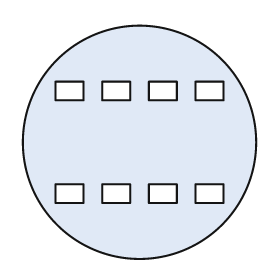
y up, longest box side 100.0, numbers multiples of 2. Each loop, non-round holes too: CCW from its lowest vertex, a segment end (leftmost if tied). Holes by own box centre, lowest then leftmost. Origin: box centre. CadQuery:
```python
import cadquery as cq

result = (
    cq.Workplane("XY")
    .moveTo(0.0, 0.0)
    .circle(50.0)
    .moveTo(-36.0, -26.0)
    .lineTo(-24.0, -26.0)
    .lineTo(-24.0, -18.0)
    .lineTo(-36.0, -18.0)
    .close()
    .moveTo(-16.0, -26.0)
    .lineTo(-4.0, -26.0)
    .lineTo(-4.0, -18.0)
    .lineTo(-16.0, -18.0)
    .close()
    .moveTo(4.0, -26.0)
    .lineTo(16.0, -26.0)
    .lineTo(16.0, -18.0)
    .lineTo(4.0, -18.0)
    .close()
    .moveTo(24.0, -26.0)
    .lineTo(36.0, -26.0)
    .lineTo(36.0, -18.0)
    .lineTo(24.0, -18.0)
    .close()
    .moveTo(-36.0, 18.0)
    .lineTo(-24.0, 18.0)
    .lineTo(-24.0, 26.0)
    .lineTo(-36.0, 26.0)
    .close()
    .moveTo(-16.0, 18.0)
    .lineTo(-4.0, 18.0)
    .lineTo(-4.0, 26.0)
    .lineTo(-16.0, 26.0)
    .close()
    .moveTo(4.0, 18.0)
    .lineTo(16.0, 18.0)
    .lineTo(16.0, 26.0)
    .lineTo(4.0, 26.0)
    .close()
    .moveTo(24.0, 18.0)
    .lineTo(36.0, 18.0)
    .lineTo(36.0, 26.0)
    .lineTo(24.0, 26.0)
    .close()
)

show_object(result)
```